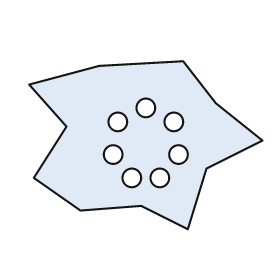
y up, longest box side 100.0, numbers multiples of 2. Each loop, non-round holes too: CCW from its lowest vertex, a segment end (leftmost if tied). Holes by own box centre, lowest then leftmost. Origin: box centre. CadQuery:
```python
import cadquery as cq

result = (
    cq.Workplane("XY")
    .moveTo(18.0, -36.0)
    .lineTo(26.0, -10.0)
    .lineTo(50.0, 2.0)
    .lineTo(30.0, 18.0)
    .lineTo(16.0, 36.0)
    .lineTo(-20.0, 34.0)
    .lineTo(-50.0, 26.0)
    .lineTo(-34.0, 8.0)
    .lineTo(-48.0, -14.0)
    .lineTo(-28.0, -28.0)
    .lineTo(-2.0, -26.0)
    .close()
    .moveTo(-6.0, -14.0)
    .circle(4.0)
    .moveTo(6.0, -14.0)
    .circle(4.0)
    .moveTo(-14.0, -4.0)
    .circle(4.0)
    .moveTo(14.0, -4.0)
    .circle(4.0)
    .moveTo(-12.0, 10.0)
    .circle(4.0)
    .moveTo(12.0, 10.0)
    .circle(4.0)
    .moveTo(0.0, 16.0)
    .circle(4.0)
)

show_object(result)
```